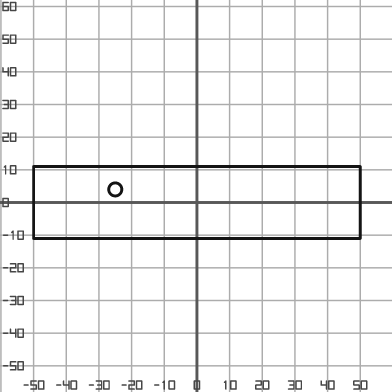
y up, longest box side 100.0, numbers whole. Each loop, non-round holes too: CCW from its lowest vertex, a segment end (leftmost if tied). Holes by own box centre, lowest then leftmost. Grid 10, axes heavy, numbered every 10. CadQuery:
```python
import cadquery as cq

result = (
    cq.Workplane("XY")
    .moveTo(-50.0, -11.0)
    .lineTo(50.0, -11.0)
    .lineTo(50.0, 11.0)
    .lineTo(-50.0, 11.0)
    .close()
    .moveTo(-25.0, 4.0)
    .circle(2.0)
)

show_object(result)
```